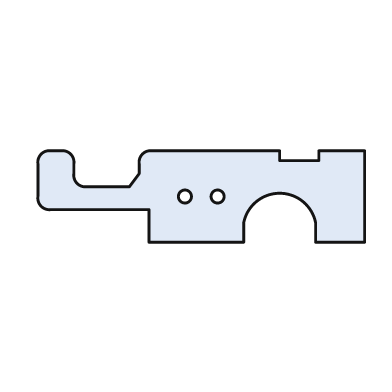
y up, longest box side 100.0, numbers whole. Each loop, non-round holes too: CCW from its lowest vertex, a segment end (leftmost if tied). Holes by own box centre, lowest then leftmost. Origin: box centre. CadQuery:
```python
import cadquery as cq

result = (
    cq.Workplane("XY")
    .moveTo(-16.0, -14.0)
    .lineTo(13.0, -14.0)
    .lineTo(13.0, -8.0)
    .threePointArc((24.0, 1.0), (35.0, -8.0))
    .lineTo(35.0, -14.0)
    .lineTo(50.0, -14.0)
    .lineTo(50.0, 14.0)
    .lineTo(36.0, 14.0)
    .lineTo(36.0, 11.0)
    .lineTo(24.0, 11.0)
    .lineTo(24.0, 14.0)
    .lineTo(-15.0, 14.0)
    .threePointArc((-18.0, 13.0), (-19.0, 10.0))
    .lineTo(-19.0, 7.0)
    .lineTo(-22.0, 3.0)
    .lineTo(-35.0, 3.0)
    .threePointArc((-38.0, 4.0), (-39.0, 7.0))
    .lineTo(-39.0, 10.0)
    .threePointArc((-40.0, 13.0), (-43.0, 14.0))
    .lineTo(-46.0, 14.0)
    .threePointArc((-49.0, 13.0), (-50.0, 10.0))
    .lineTo(-50.0, 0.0)
    .threePointArc((-49.0, -3.0), (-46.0, -4.0))
    .lineTo(-16.0, -4.0)
    .close()
    .moveTo(-5.0, 0.0)
    .circle(2.0)
    .moveTo(5.0, 0.0)
    .circle(2.0)
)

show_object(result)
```